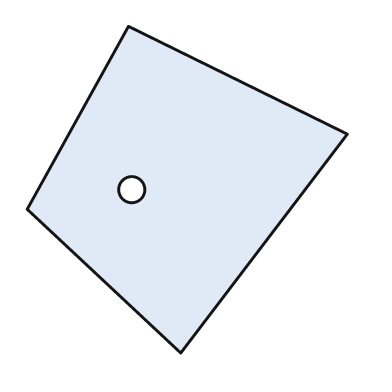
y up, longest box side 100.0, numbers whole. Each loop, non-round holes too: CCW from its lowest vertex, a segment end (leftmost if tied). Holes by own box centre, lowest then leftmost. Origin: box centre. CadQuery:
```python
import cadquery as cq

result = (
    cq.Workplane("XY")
    .moveTo(-2.0, -50.0)
    .lineTo(49.0, 17.0)
    .lineTo(-18.0, 50.0)
    .lineTo(-49.0, -6.0)
    .close()
    .moveTo(-17.0, 0.0)
    .circle(4.0)
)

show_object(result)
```